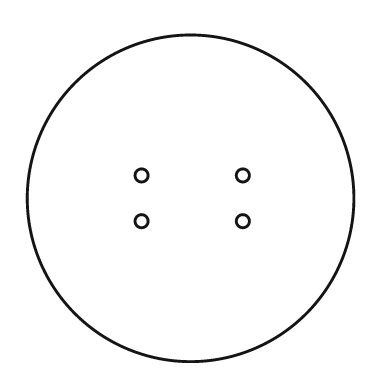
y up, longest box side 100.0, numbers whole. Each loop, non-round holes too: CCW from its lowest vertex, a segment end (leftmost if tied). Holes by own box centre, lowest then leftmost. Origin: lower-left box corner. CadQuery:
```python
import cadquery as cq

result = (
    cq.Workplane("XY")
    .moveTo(50.0, 50.0)
    .circle(50.0)
    .moveTo(35.0, 43.0)
    .circle(2.0)
    .moveTo(66.0, 43.0)
    .circle(2.0)
    .moveTo(35.0, 57.0)
    .circle(2.0)
    .moveTo(66.0, 57.0)
    .circle(2.0)
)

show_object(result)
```